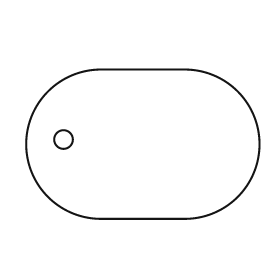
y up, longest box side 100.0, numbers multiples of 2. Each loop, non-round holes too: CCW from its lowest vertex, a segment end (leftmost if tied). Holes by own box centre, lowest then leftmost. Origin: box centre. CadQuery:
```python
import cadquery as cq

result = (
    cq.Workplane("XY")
    .moveTo(-18.0, -32.0)
    .lineTo(18.0, -32.0)
    .threePointArc((50.0, 0.0), (18.0, 32.0))
    .lineTo(-18.0, 32.0)
    .threePointArc((-50.0, 0.0), (-18.0, -32.0))
    .close()
    .moveTo(-34.0, 2.0)
    .circle(4.0)
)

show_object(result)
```